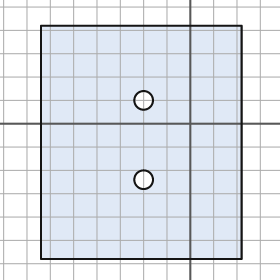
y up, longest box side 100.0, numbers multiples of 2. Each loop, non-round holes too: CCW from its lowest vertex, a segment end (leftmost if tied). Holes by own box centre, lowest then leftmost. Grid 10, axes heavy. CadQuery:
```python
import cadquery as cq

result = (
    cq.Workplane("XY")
    .moveTo(-64.0, -58.0)
    .lineTo(22.0, -58.0)
    .lineTo(22.0, 42.0)
    .lineTo(-64.0, 42.0)
    .close()
    .moveTo(-20.0, -24.0)
    .circle(4.0)
    .moveTo(-20.0, 10.0)
    .circle(4.0)
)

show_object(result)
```